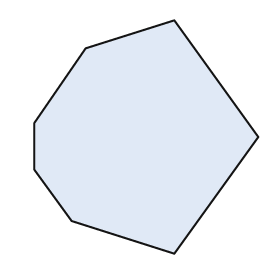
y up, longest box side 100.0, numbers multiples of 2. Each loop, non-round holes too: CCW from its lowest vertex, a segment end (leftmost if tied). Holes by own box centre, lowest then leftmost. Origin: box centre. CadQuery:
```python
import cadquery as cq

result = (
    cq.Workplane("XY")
    .moveTo(12.0, -50.0)
    .lineTo(48.0, 0.0)
    .lineTo(12.0, 50.0)
    .lineTo(-26.0, 38.0)
    .lineTo(-48.0, 6.0)
    .lineTo(-48.0, -14.0)
    .lineTo(-32.0, -36.0)
    .close()
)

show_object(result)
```